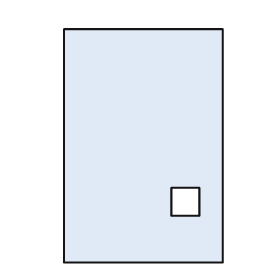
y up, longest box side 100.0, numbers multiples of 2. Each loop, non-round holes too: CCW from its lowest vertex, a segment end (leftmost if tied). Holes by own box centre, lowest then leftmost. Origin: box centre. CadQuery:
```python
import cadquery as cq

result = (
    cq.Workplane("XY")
    .moveTo(-34.0, -50.0)
    .lineTo(34.0, -50.0)
    .lineTo(34.0, 50.0)
    .lineTo(-34.0, 50.0)
    .close()
    .moveTo(12.0, -30.0)
    .lineTo(24.0, -30.0)
    .lineTo(24.0, -18.0)
    .lineTo(12.0, -18.0)
    .close()
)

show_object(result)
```